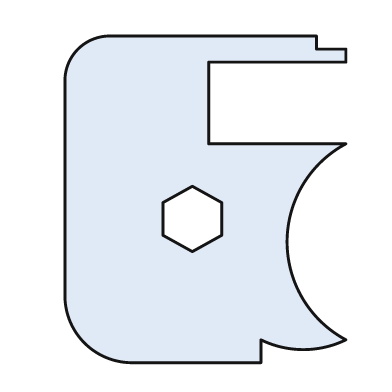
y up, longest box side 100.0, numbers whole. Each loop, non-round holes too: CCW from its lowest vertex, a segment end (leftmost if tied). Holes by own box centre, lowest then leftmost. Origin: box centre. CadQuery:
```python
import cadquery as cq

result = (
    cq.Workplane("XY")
    .moveTo(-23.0, -50.0)
    .lineTo(17.0, -50.0)
    .lineTo(17.0, -43.0)
    .threePointArc((30.0, -46.0), (43.0, -43.0))
    .threePointArc((25.0, -13.0), (43.0, 17.0))
    .lineTo(1.0, 17.0)
    .lineTo(1.0, 42.0)
    .lineTo(43.0, 42.0)
    .lineTo(43.0, 46.0)
    .lineTo(34.0, 46.0)
    .lineTo(34.0, 50.0)
    .lineTo(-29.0, 50.0)
    .threePointArc((-39.0, 46.0), (-43.0, 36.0))
    .lineTo(-43.0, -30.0)
    .threePointArc((-37.0, -44.0), (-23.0, -50.0))
    .close()
    .moveTo(-4.0, -16.0)
    .lineTo(5.0, -11.0)
    .lineTo(5.0, -1.0)
    .lineTo(-4.0, 4.0)
    .lineTo(-13.0, -1.0)
    .lineTo(-13.0, -11.0)
    .close()
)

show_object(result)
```